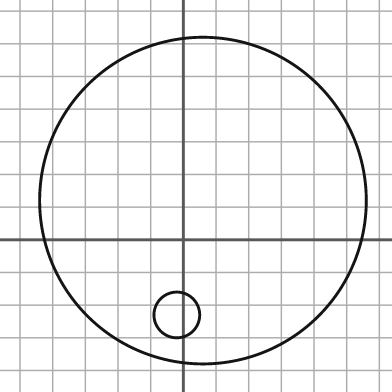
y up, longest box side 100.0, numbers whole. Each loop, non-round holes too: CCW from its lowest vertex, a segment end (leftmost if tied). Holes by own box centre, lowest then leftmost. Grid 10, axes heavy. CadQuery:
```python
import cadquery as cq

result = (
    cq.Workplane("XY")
    .moveTo(6.0, 12.0)
    .circle(50.0)
    .moveTo(-2.0, -23.0)
    .circle(7.0)
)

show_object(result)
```